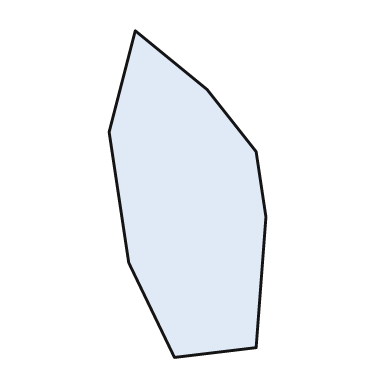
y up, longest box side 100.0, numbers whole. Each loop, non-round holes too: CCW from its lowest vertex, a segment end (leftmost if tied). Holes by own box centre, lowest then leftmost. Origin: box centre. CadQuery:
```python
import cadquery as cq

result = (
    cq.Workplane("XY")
    .moveTo(-4.0, -50.0)
    .lineTo(21.0, -47.0)
    .lineTo(24.0, -7.0)
    .lineTo(21.0, 13.0)
    .lineTo(6.0, 32.0)
    .lineTo(-16.0, 50.0)
    .lineTo(-24.0, 19.0)
    .lineTo(-18.0, -21.0)
    .close()
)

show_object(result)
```